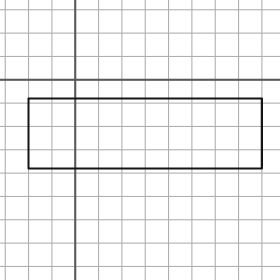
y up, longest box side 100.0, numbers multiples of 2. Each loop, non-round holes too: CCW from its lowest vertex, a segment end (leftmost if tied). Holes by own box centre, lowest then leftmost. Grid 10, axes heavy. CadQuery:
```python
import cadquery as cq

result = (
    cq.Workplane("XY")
    .moveTo(-20.0, -38.0)
    .lineTo(80.0, -38.0)
    .lineTo(80.0, -8.0)
    .lineTo(-20.0, -8.0)
    .close()
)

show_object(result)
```